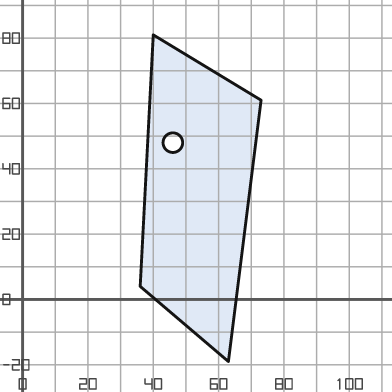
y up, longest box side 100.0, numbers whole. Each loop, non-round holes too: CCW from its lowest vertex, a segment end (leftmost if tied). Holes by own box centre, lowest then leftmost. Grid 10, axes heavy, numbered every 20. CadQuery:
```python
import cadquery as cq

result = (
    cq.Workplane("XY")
    .moveTo(63.0, -19.0)
    .lineTo(73.0, 61.0)
    .lineTo(40.0, 81.0)
    .lineTo(36.0, 4.0)
    .close()
    .moveTo(46.0, 48.0)
    .circle(3.0)
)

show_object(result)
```